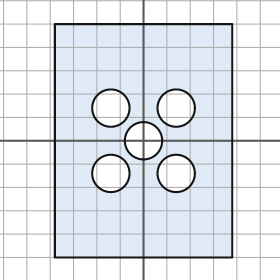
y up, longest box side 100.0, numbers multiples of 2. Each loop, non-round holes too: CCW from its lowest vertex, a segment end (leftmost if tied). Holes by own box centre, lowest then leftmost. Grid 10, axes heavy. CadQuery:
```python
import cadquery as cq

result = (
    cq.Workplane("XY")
    .moveTo(-38.0, -50.0)
    .lineTo(38.0, -50.0)
    .lineTo(38.0, 50.0)
    .lineTo(-38.0, 50.0)
    .close()
    .moveTo(-14.0, -14.0)
    .circle(8.0)
    .moveTo(14.0, -14.0)
    .circle(8.0)
    .moveTo(0.0, 0.0)
    .circle(8.0)
    .moveTo(-14.0, 14.0)
    .circle(8.0)
    .moveTo(14.0, 14.0)
    .circle(8.0)
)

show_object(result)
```